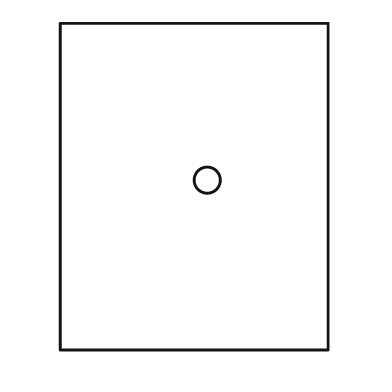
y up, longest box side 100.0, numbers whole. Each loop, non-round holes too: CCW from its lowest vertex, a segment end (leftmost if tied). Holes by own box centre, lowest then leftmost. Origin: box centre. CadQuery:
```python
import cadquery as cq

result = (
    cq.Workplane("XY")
    .moveTo(-41.0, -50.0)
    .lineTo(41.0, -50.0)
    .lineTo(41.0, 50.0)
    .lineTo(-41.0, 50.0)
    .close()
    .moveTo(4.0, 2.0)
    .circle(4.0)
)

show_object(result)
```